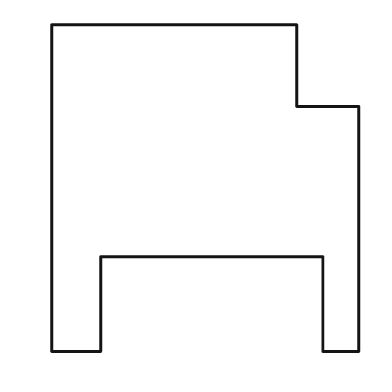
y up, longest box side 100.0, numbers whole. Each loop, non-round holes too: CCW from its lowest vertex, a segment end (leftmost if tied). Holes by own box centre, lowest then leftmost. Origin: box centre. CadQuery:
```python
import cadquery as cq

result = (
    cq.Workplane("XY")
    .moveTo(-47.0, -50.0)
    .lineTo(-32.0, -50.0)
    .lineTo(-32.0, -21.0)
    .lineTo(36.0, -21.0)
    .lineTo(36.0, -50.0)
    .lineTo(47.0, -50.0)
    .lineTo(47.0, 25.0)
    .lineTo(28.0, 25.0)
    .lineTo(28.0, 50.0)
    .lineTo(-47.0, 50.0)
    .close()
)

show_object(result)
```